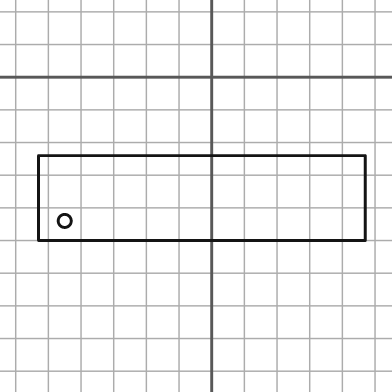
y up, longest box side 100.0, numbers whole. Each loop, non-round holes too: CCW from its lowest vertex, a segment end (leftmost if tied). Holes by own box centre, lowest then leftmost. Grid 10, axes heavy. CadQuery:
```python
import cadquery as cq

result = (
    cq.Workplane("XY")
    .moveTo(-53.0, -50.0)
    .lineTo(47.0, -50.0)
    .lineTo(47.0, -24.0)
    .lineTo(-53.0, -24.0)
    .close()
    .moveTo(-45.0, -44.0)
    .circle(2.0)
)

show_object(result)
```